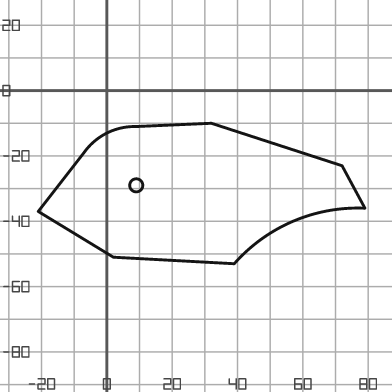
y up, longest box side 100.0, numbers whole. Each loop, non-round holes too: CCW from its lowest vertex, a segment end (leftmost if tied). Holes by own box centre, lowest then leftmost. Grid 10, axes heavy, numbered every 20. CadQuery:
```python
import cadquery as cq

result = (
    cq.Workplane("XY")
    .moveTo(39.0, -53.0)
    .threePointArc((57.0, -40.0), (79.0, -36.0))
    .lineTo(72.0, -23.0)
    .lineTo(32.0, -10.0)
    .lineTo(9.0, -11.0)
    .threePointArc((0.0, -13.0), (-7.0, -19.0))
    .lineTo(-21.0, -37.0)
    .lineTo(2.0, -51.0)
    .close()
    .moveTo(9.0, -29.0)
    .circle(2.0)
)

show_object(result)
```